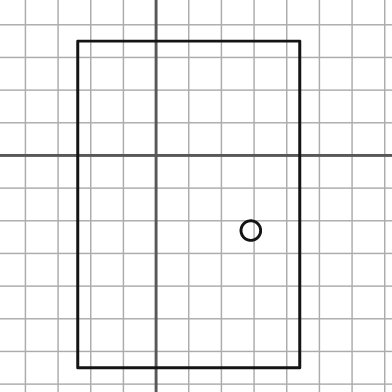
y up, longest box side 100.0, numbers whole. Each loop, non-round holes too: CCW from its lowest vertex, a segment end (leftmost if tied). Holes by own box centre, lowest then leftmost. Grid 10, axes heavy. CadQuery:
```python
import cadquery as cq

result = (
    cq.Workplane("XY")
    .moveTo(-24.0, -65.0)
    .lineTo(44.0, -65.0)
    .lineTo(44.0, 35.0)
    .lineTo(-24.0, 35.0)
    .close()
    .moveTo(29.0, -23.0)
    .circle(3.0)
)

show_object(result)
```